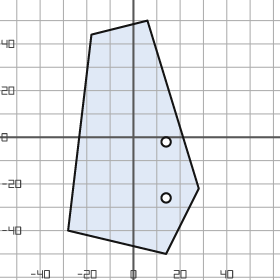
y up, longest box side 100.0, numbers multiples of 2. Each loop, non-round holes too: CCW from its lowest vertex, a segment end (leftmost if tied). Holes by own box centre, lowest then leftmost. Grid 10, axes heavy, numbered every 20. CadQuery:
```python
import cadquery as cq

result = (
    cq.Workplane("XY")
    .moveTo(14.0, -50.0)
    .lineTo(28.0, -22.0)
    .lineTo(6.0, 50.0)
    .lineTo(-18.0, 44.0)
    .lineTo(-28.0, -40.0)
    .close()
    .moveTo(14.0, -26.0)
    .circle(2.0)
    .moveTo(14.0, -2.0)
    .circle(2.0)
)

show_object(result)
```